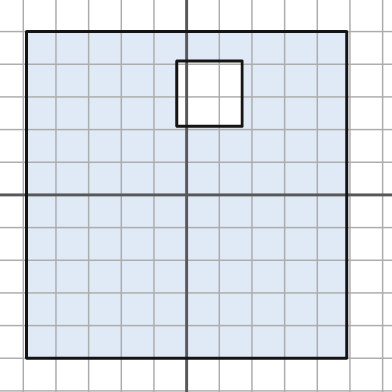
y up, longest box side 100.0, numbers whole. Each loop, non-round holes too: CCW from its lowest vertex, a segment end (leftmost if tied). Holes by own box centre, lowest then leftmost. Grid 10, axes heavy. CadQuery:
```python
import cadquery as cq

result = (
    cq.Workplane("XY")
    .moveTo(-49.0, -50.0)
    .lineTo(49.0, -50.0)
    .lineTo(49.0, 50.0)
    .lineTo(-49.0, 50.0)
    .close()
    .moveTo(-3.0, 21.0)
    .lineTo(17.0, 21.0)
    .lineTo(17.0, 41.0)
    .lineTo(-3.0, 41.0)
    .close()
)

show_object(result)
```